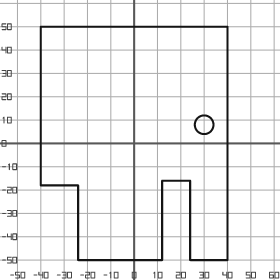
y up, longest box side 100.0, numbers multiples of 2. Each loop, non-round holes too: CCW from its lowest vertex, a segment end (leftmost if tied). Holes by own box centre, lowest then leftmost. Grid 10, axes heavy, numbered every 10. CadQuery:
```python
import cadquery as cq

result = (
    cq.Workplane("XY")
    .moveTo(-24.0, -50.0)
    .lineTo(12.0, -50.0)
    .lineTo(12.0, -16.0)
    .lineTo(24.0, -16.0)
    .lineTo(24.0, -50.0)
    .lineTo(40.0, -50.0)
    .lineTo(40.0, 50.0)
    .lineTo(-40.0, 50.0)
    .lineTo(-40.0, -18.0)
    .lineTo(-24.0, -18.0)
    .close()
    .moveTo(30.0, 8.0)
    .circle(4.0)
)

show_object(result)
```